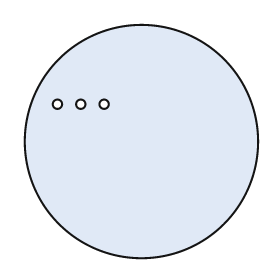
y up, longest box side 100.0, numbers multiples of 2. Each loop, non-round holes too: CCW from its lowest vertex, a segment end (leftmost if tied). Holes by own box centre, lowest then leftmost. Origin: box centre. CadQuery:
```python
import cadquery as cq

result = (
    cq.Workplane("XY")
    .moveTo(0.0, 0.0)
    .circle(50.0)
    .moveTo(-36.0, 16.0)
    .circle(2.0)
    .moveTo(-26.0, 16.0)
    .circle(2.0)
    .moveTo(-16.0, 16.0)
    .circle(2.0)
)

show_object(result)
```